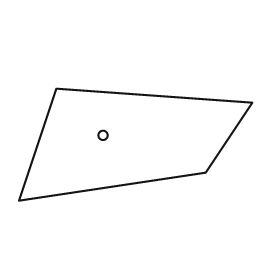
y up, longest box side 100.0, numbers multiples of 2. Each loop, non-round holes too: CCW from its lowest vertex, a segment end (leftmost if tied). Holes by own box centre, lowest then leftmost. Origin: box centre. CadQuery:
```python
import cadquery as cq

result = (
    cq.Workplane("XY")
    .moveTo(-50.0, -24.0)
    .lineTo(30.0, -12.0)
    .lineTo(50.0, 18.0)
    .lineTo(-34.0, 24.0)
    .close()
    .moveTo(-14.0, 4.0)
    .circle(2.0)
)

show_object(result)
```